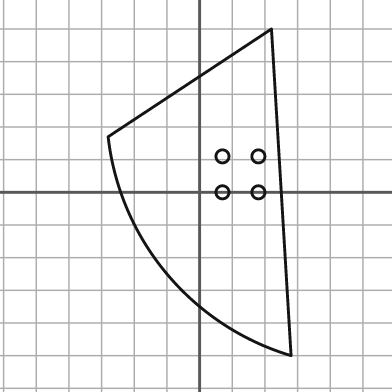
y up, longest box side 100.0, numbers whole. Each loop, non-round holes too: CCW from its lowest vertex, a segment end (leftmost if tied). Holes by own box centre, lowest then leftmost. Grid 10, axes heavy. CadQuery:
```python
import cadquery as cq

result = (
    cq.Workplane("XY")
    .moveTo(28.0, -50.0)
    .lineTo(22.0, 50.0)
    .lineTo(-28.0, 17.0)
    .threePointArc((-10.0, -25.0), (28.0, -50.0))
    .close()
    .moveTo(7.0, 0.0)
    .circle(2.0)
    .moveTo(18.0, 0.0)
    .circle(2.0)
    .moveTo(7.0, 11.0)
    .circle(2.0)
    .moveTo(18.0, 11.0)
    .circle(2.0)
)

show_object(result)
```